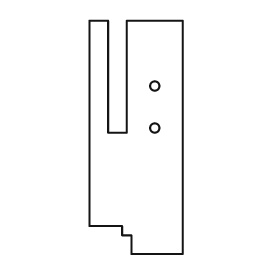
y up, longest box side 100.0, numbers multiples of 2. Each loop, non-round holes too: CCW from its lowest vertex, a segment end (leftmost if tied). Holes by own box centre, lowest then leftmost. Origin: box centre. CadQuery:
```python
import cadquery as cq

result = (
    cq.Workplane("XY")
    .moveTo(-2.0, -50.0)
    .lineTo(20.0, -50.0)
    .lineTo(20.0, 50.0)
    .lineTo(-4.0, 50.0)
    .lineTo(-4.0, 2.0)
    .lineTo(-12.0, 2.0)
    .lineTo(-12.0, 50.0)
    .lineTo(-20.0, 50.0)
    .lineTo(-20.0, -38.0)
    .lineTo(-6.0, -38.0)
    .lineTo(-6.0, -42.0)
    .lineTo(-2.0, -42.0)
    .close()
    .moveTo(8.0, 4.0)
    .circle(2.0)
    .moveTo(8.0, 22.0)
    .circle(2.0)
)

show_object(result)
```